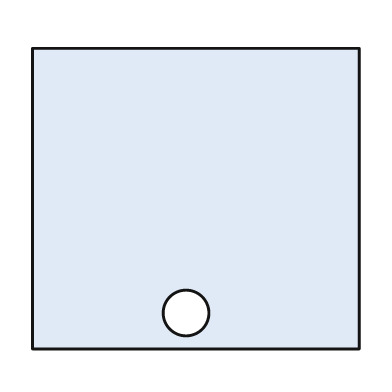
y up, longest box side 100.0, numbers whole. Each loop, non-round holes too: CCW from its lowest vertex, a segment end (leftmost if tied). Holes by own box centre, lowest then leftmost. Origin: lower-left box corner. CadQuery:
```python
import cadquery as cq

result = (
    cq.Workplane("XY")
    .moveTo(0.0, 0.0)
    .lineTo(100.0, 0.0)
    .lineTo(100.0, 92.0)
    .lineTo(0.0, 92.0)
    .close()
    .moveTo(47.0, 11.0)
    .circle(7.0)
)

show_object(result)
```